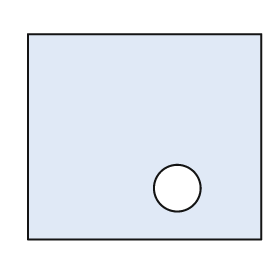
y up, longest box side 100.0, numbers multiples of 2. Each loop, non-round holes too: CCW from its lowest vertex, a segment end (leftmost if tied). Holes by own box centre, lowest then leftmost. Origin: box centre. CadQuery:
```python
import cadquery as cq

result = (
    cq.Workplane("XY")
    .moveTo(-50.0, -44.0)
    .lineTo(50.0, -44.0)
    .lineTo(50.0, 44.0)
    .lineTo(-50.0, 44.0)
    .close()
    .moveTo(14.0, -22.0)
    .circle(10.0)
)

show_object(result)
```